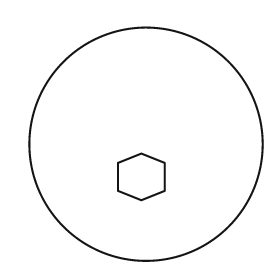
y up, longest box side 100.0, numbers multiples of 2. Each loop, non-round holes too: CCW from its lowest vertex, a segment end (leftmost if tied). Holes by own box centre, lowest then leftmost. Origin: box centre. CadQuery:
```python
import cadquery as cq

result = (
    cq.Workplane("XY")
    .moveTo(0.0, 0.0)
    .circle(50.0)
    .moveTo(-2.0, -24.0)
    .lineTo(8.0, -20.0)
    .lineTo(8.0, -8.0)
    .lineTo(-2.0, -4.0)
    .lineTo(-12.0, -8.0)
    .lineTo(-12.0, -20.0)
    .close()
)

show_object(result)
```